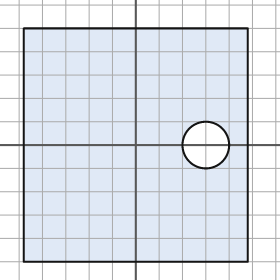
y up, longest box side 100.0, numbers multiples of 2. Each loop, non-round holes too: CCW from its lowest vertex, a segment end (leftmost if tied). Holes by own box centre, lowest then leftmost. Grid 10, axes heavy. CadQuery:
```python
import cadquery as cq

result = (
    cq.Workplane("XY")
    .moveTo(-48.0, -50.0)
    .lineTo(48.0, -50.0)
    .lineTo(48.0, 50.0)
    .lineTo(-48.0, 50.0)
    .close()
    .moveTo(30.0, 0.0)
    .circle(10.0)
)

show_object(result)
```